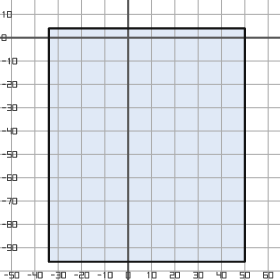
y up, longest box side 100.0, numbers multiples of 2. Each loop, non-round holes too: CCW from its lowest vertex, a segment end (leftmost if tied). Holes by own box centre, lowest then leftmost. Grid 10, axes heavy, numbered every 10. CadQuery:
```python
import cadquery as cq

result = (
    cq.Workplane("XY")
    .moveTo(-34.0, -96.0)
    .lineTo(50.0, -96.0)
    .lineTo(50.0, 4.0)
    .lineTo(-34.0, 4.0)
    .close()
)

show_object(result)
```